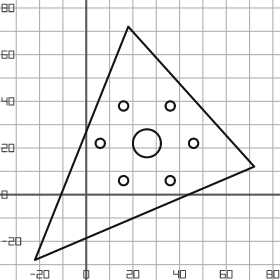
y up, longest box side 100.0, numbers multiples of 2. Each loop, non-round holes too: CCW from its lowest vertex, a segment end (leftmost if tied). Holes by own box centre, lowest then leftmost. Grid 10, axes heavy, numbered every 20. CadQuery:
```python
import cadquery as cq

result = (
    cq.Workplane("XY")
    .moveTo(-22.0, -28.0)
    .lineTo(72.0, 12.0)
    .lineTo(18.0, 72.0)
    .close()
    .moveTo(16.0, 6.0)
    .circle(2.0)
    .moveTo(36.0, 6.0)
    .circle(2.0)
    .moveTo(6.0, 22.0)
    .circle(2.0)
    .moveTo(26.0, 22.0)
    .circle(6.0)
    .moveTo(46.0, 22.0)
    .circle(2.0)
    .moveTo(16.0, 38.0)
    .circle(2.0)
    .moveTo(36.0, 38.0)
    .circle(2.0)
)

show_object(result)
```